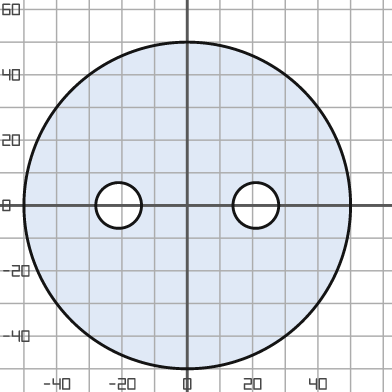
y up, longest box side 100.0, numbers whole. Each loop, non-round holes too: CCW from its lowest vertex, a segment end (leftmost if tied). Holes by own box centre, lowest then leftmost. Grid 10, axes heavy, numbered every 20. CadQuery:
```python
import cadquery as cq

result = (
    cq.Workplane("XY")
    .moveTo(0.0, 0.0)
    .circle(50.0)
    .moveTo(-21.0, 0.0)
    .circle(7.0)
    .moveTo(21.0, 0.0)
    .circle(7.0)
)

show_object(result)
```